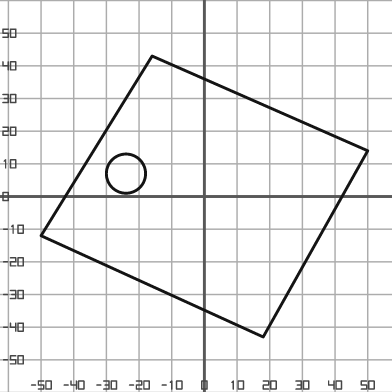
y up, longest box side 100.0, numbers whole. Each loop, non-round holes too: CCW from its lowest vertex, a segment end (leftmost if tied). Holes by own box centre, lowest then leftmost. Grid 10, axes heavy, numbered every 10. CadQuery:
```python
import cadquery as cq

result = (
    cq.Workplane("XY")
    .moveTo(18.0, -43.0)
    .lineTo(50.0, 14.0)
    .lineTo(-16.0, 43.0)
    .lineTo(-50.0, -12.0)
    .close()
    .moveTo(-24.0, 7.0)
    .circle(6.0)
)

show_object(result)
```